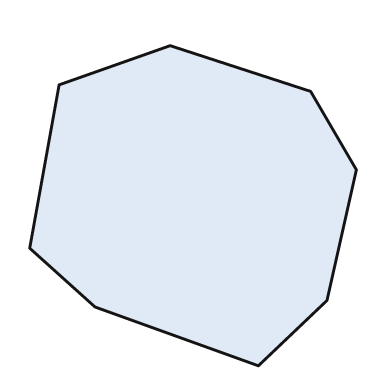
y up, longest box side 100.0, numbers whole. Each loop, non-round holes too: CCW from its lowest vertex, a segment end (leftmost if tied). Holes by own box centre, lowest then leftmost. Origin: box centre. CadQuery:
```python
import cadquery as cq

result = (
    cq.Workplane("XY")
    .moveTo(20.0, -49.0)
    .lineTo(41.0, -29.0)
    .lineTo(50.0, 11.0)
    .lineTo(36.0, 35.0)
    .lineTo(-7.0, 49.0)
    .lineTo(-41.0, 37.0)
    .lineTo(-50.0, -13.0)
    .lineTo(-30.0, -31.0)
    .close()
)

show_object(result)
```